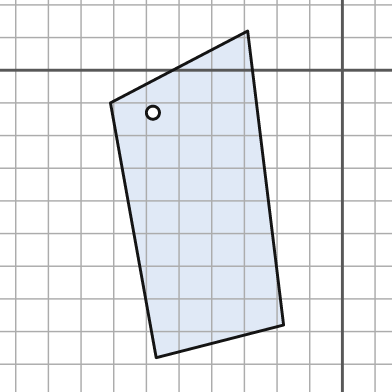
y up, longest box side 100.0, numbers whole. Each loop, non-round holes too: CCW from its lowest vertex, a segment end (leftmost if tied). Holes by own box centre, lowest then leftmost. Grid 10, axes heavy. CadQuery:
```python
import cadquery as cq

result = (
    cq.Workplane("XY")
    .moveTo(-57.0, -88.0)
    .lineTo(-18.0, -78.0)
    .lineTo(-29.0, 12.0)
    .lineTo(-71.0, -10.0)
    .close()
    .moveTo(-58.0, -13.0)
    .circle(2.0)
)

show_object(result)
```